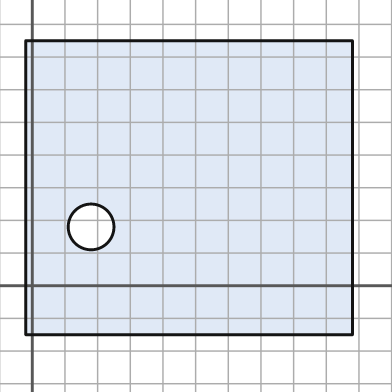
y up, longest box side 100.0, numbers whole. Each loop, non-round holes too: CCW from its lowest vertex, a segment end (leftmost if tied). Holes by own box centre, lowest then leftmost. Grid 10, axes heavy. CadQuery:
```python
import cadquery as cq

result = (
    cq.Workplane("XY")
    .moveTo(-2.0, -15.0)
    .lineTo(98.0, -15.0)
    .lineTo(98.0, 75.0)
    .lineTo(-2.0, 75.0)
    .close()
    .moveTo(18.0, 18.0)
    .circle(7.0)
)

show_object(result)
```